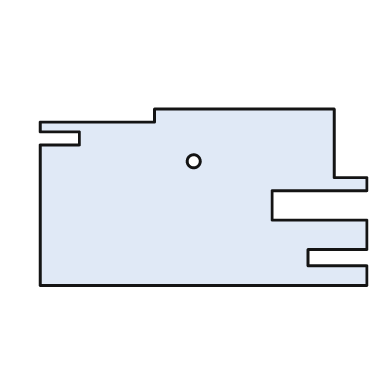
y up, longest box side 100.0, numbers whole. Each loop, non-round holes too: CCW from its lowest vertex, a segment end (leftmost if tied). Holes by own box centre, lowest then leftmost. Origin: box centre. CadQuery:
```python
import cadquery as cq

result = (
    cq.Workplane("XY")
    .moveTo(-50.0, -27.0)
    .lineTo(50.0, -27.0)
    .lineTo(50.0, -21.0)
    .lineTo(32.0, -21.0)
    .lineTo(32.0, -16.0)
    .lineTo(50.0, -16.0)
    .lineTo(50.0, -7.0)
    .lineTo(21.0, -7.0)
    .lineTo(21.0, 2.0)
    .lineTo(50.0, 2.0)
    .lineTo(50.0, 6.0)
    .lineTo(40.0, 6.0)
    .lineTo(40.0, 27.0)
    .lineTo(-15.0, 27.0)
    .lineTo(-15.0, 23.0)
    .lineTo(-50.0, 23.0)
    .lineTo(-50.0, 20.0)
    .lineTo(-38.0, 20.0)
    .lineTo(-38.0, 16.0)
    .lineTo(-50.0, 16.0)
    .close()
    .moveTo(-3.0, 11.0)
    .circle(2.0)
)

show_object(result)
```